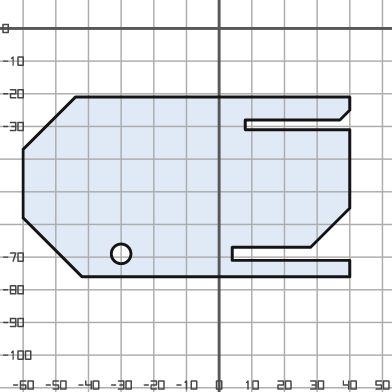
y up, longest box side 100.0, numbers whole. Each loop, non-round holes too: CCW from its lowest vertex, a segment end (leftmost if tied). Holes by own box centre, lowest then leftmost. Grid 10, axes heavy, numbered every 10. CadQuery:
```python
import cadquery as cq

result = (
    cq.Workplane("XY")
    .moveTo(-42.0, -76.0)
    .lineTo(40.0, -76.0)
    .lineTo(40.0, -71.0)
    .lineTo(4.0, -71.0)
    .lineTo(4.0, -67.0)
    .lineTo(28.0, -67.0)
    .lineTo(40.0, -55.0)
    .lineTo(40.0, -31.0)
    .lineTo(8.0, -31.0)
    .lineTo(8.0, -28.0)
    .lineTo(37.0, -28.0)
    .lineTo(40.0, -25.0)
    .lineTo(40.0, -21.0)
    .lineTo(-44.0, -21.0)
    .lineTo(-60.0, -37.0)
    .lineTo(-60.0, -58.0)
    .close()
    .moveTo(-30.0, -69.0)
    .circle(3.0)
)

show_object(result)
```